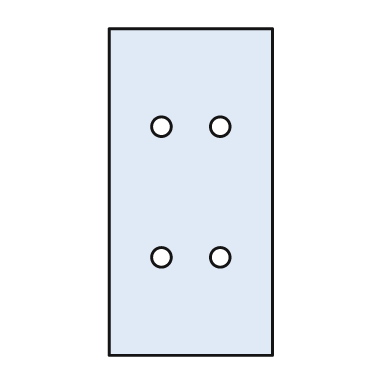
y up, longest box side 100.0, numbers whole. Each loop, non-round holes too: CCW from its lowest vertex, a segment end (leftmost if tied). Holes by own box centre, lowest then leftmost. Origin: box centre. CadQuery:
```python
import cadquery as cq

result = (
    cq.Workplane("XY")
    .moveTo(-25.0, -50.0)
    .lineTo(25.0, -50.0)
    .lineTo(25.0, 50.0)
    .lineTo(-25.0, 50.0)
    .close()
    .moveTo(-9.0, -20.0)
    .circle(3.0)
    .moveTo(9.0, -20.0)
    .circle(3.0)
    .moveTo(-9.0, 20.0)
    .circle(3.0)
    .moveTo(9.0, 20.0)
    .circle(3.0)
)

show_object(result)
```